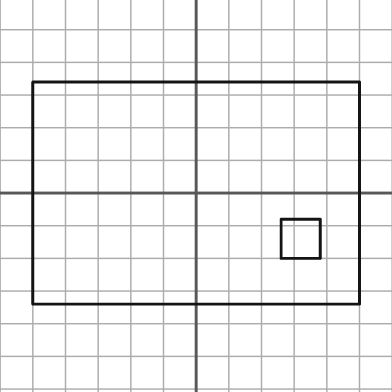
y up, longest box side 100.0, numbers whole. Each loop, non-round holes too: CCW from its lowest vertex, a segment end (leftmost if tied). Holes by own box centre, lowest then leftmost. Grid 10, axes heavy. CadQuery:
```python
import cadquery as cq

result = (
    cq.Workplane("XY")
    .moveTo(-50.0, -34.0)
    .lineTo(50.0, -34.0)
    .lineTo(50.0, 34.0)
    .lineTo(-50.0, 34.0)
    .close()
    .moveTo(26.0, -20.0)
    .lineTo(38.0, -20.0)
    .lineTo(38.0, -8.0)
    .lineTo(26.0, -8.0)
    .close()
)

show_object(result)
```